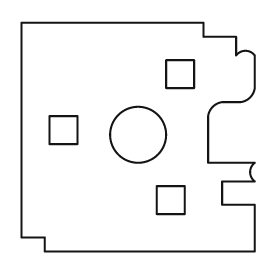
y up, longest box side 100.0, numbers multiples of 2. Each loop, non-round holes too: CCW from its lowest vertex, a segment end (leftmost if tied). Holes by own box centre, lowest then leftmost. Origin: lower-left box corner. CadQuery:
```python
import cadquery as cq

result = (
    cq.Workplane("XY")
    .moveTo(10.0, 0.0)
    .lineTo(100.0, 0.0)
    .lineTo(100.0, 20.0)
    .lineTo(86.0, 20.0)
    .lineTo(86.0, 30.0)
    .lineTo(100.0, 30.0)
    .threePointArc((98.0, 34.0), (100.0, 38.0))
    .lineTo(80.0, 38.0)
    .lineTo(80.0, 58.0)
    .threePointArc((82.0, 62.0), (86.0, 64.0))
    .lineTo(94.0, 64.0)
    .threePointArc((98.0, 66.0), (100.0, 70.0))
    .lineTo(100.0, 84.0)
    .threePointArc((96.0, 86.0), (92.0, 84.0))
    .lineTo(92.0, 92.0)
    .lineTo(78.0, 92.0)
    .lineTo(78.0, 98.0)
    .lineTo(0.0, 98.0)
    .lineTo(0.0, 6.0)
    .lineTo(10.0, 6.0)
    .close()
    .moveTo(58.0, 16.0)
    .lineTo(70.0, 16.0)
    .lineTo(70.0, 28.0)
    .lineTo(58.0, 28.0)
    .close()
    .moveTo(50.0, 50.0)
    .circle(12.0)
    .moveTo(12.0, 46.0)
    .lineTo(24.0, 46.0)
    .lineTo(24.0, 58.0)
    .lineTo(12.0, 58.0)
    .close()
    .moveTo(62.0, 70.0)
    .lineTo(74.0, 70.0)
    .lineTo(74.0, 82.0)
    .lineTo(62.0, 82.0)
    .close()
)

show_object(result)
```